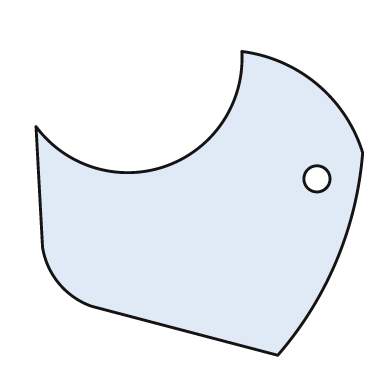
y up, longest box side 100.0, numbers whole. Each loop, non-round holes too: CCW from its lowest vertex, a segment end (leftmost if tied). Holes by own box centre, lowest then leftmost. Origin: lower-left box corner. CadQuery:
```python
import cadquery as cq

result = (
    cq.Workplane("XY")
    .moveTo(74.0, 0.0)
    .threePointArc((92.0, 29.0), (100.0, 62.0))
    .threePointArc((86.0, 83.0), (63.0, 93.0))
    .threePointArc((40.0, 58.0), (0.0, 70.0))
    .lineTo(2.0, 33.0)
    .threePointArc((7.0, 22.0), (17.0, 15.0))
    .close()
    .moveTo(86.0, 54.0)
    .circle(4.0)
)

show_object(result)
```